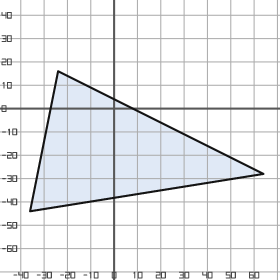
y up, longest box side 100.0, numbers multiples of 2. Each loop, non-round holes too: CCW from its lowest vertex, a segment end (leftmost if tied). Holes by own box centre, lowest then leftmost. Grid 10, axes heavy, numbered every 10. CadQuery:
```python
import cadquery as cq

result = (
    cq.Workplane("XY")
    .moveTo(-36.0, -44.0)
    .lineTo(64.0, -28.0)
    .lineTo(-24.0, 16.0)
    .close()
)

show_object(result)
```